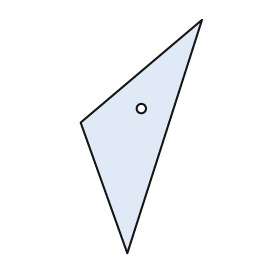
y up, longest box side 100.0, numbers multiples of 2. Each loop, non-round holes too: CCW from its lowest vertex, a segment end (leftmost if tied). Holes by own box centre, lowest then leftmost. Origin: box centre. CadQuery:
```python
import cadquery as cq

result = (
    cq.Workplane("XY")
    .moveTo(-6.0, -50.0)
    .lineTo(26.0, 50.0)
    .lineTo(-26.0, 6.0)
    .close()
    .moveTo(0.0, 12.0)
    .circle(2.0)
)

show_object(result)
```